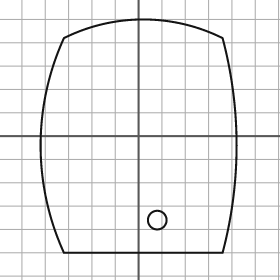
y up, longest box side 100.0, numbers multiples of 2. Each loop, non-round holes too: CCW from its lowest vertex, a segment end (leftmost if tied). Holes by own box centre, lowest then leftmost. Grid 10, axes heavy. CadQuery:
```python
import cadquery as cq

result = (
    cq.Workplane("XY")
    .moveTo(-32.0, -50.0)
    .lineTo(36.0, -50.0)
    .threePointArc((42.0, -4.0), (36.0, 42.0))
    .threePointArc((2.0, 50.0), (-32.0, 42.0))
    .threePointArc((-42.0, -4.0), (-32.0, -50.0))
    .close()
    .moveTo(8.0, -36.0)
    .circle(4.0)
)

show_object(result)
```